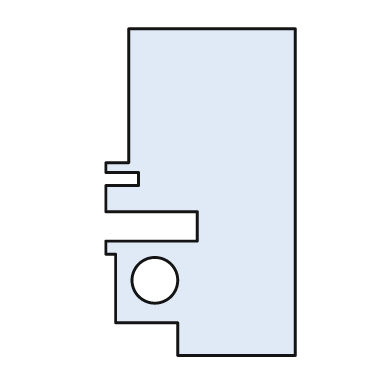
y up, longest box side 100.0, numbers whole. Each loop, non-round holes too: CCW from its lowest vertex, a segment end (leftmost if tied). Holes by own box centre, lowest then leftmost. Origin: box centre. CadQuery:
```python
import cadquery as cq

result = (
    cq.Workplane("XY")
    .moveTo(-7.0, -50.0)
    .lineTo(29.0, -50.0)
    .lineTo(29.0, 50.0)
    .lineTo(-22.0, 50.0)
    .lineTo(-22.0, 9.0)
    .lineTo(-29.0, 9.0)
    .lineTo(-29.0, 6.0)
    .lineTo(-19.0, 6.0)
    .lineTo(-19.0, 2.0)
    .lineTo(-29.0, 2.0)
    .lineTo(-29.0, -6.0)
    .lineTo(-1.0, -6.0)
    .lineTo(-1.0, -15.0)
    .lineTo(-29.0, -15.0)
    .lineTo(-29.0, -19.0)
    .lineTo(-26.0, -19.0)
    .lineTo(-26.0, -40.0)
    .lineTo(-7.0, -40.0)
    .close()
    .moveTo(-14.0, -27.0)
    .circle(7.0)
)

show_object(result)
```